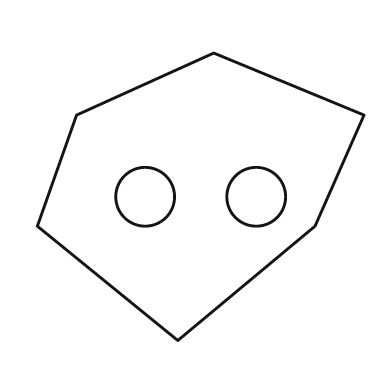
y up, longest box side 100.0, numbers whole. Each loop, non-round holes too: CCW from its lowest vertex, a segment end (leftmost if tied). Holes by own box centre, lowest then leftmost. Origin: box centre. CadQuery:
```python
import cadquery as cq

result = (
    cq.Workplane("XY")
    .moveTo(-7.0, -44.0)
    .lineTo(35.0, -9.0)
    .lineTo(50.0, 25.0)
    .lineTo(4.0, 44.0)
    .lineTo(-38.0, 25.0)
    .lineTo(-50.0, -9.0)
    .close()
    .moveTo(-17.0, 0.0)
    .circle(9.0)
    .moveTo(17.0, 0.0)
    .circle(9.0)
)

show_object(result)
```